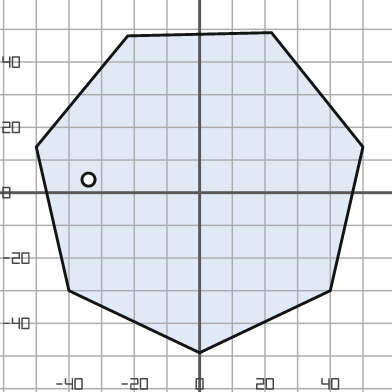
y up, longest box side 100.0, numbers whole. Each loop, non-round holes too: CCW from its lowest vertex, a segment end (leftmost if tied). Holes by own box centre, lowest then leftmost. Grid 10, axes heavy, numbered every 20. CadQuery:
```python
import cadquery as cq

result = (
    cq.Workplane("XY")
    .moveTo(0.0, -49.0)
    .lineTo(40.0, -30.0)
    .lineTo(50.0, 14.0)
    .lineTo(22.0, 49.0)
    .lineTo(-22.0, 48.0)
    .lineTo(-50.0, 14.0)
    .lineTo(-40.0, -30.0)
    .close()
    .moveTo(-34.0, 4.0)
    .circle(2.0)
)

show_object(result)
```